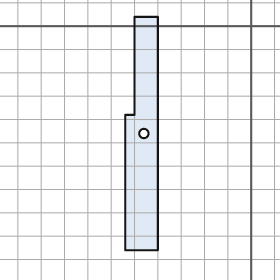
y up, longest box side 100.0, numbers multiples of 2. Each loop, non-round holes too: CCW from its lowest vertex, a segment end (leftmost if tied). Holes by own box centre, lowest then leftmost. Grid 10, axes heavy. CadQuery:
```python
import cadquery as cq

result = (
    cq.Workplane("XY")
    .moveTo(-54.0, -96.0)
    .lineTo(-40.0, -96.0)
    .lineTo(-40.0, 4.0)
    .lineTo(-50.0, 4.0)
    .lineTo(-50.0, -38.0)
    .lineTo(-54.0, -38.0)
    .close()
    .moveTo(-46.0, -46.0)
    .circle(2.0)
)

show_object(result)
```